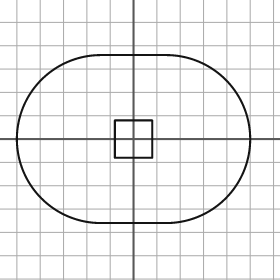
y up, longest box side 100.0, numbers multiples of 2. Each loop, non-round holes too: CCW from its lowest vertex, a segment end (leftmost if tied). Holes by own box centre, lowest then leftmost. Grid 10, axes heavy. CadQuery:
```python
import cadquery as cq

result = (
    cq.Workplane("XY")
    .moveTo(-14.0, -36.0)
    .lineTo(14.0, -36.0)
    .threePointArc((50.0, 0.0), (14.0, 36.0))
    .lineTo(-14.0, 36.0)
    .threePointArc((-50.0, 0.0), (-14.0, -36.0))
    .close()
    .moveTo(-8.0, -8.0)
    .lineTo(8.0, -8.0)
    .lineTo(8.0, 8.0)
    .lineTo(-8.0, 8.0)
    .close()
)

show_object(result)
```